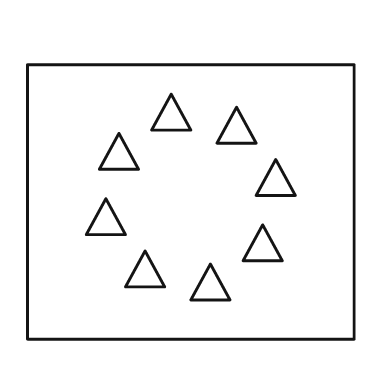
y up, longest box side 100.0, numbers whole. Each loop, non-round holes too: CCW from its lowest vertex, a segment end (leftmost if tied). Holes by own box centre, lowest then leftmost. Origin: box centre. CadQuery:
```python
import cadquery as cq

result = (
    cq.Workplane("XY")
    .moveTo(-50.0, -42.0)
    .lineTo(50.0, -42.0)
    .lineTo(50.0, 42.0)
    .lineTo(-50.0, 42.0)
    .close()
    .moveTo(0.0, -30.0)
    .lineTo(12.0, -30.0)
    .lineTo(6.0, -19.0)
    .close()
    .moveTo(-20.0, -26.0)
    .lineTo(-8.0, -26.0)
    .lineTo(-14.0, -15.0)
    .close()
    .moveTo(16.0, -18.0)
    .lineTo(28.0, -18.0)
    .lineTo(22.0, -7.0)
    .close()
    .moveTo(-32.0, -10.0)
    .lineTo(-20.0, -10.0)
    .lineTo(-26.0, 1.0)
    .close()
    .moveTo(20.0, 2.0)
    .lineTo(32.0, 2.0)
    .lineTo(26.0, 13.0)
    .close()
    .moveTo(-28.0, 10.0)
    .lineTo(-16.0, 10.0)
    .lineTo(-22.0, 21.0)
    .close()
    .moveTo(8.0, 18.0)
    .lineTo(20.0, 18.0)
    .lineTo(14.0, 29.0)
    .close()
    .moveTo(-12.0, 22.0)
    .lineTo(0.0, 22.0)
    .lineTo(-6.0, 33.0)
    .close()
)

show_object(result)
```